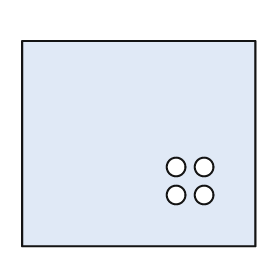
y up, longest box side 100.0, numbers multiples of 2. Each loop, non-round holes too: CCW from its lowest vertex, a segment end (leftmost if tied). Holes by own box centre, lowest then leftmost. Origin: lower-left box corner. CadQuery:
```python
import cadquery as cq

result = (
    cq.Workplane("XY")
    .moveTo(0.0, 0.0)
    .lineTo(100.0, 0.0)
    .lineTo(100.0, 88.0)
    .lineTo(0.0, 88.0)
    .close()
    .moveTo(66.0, 22.0)
    .circle(4.0)
    .moveTo(78.0, 22.0)
    .circle(4.0)
    .moveTo(66.0, 34.0)
    .circle(4.0)
    .moveTo(78.0, 34.0)
    .circle(4.0)
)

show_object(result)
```